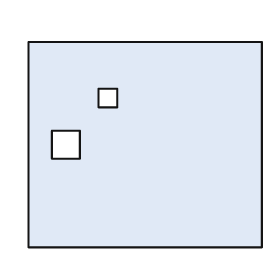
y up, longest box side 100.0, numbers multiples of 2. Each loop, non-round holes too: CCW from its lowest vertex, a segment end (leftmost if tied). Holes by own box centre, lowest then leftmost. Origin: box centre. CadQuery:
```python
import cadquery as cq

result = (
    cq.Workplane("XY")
    .moveTo(-50.0, -44.0)
    .lineTo(50.0, -44.0)
    .lineTo(50.0, 44.0)
    .lineTo(-50.0, 44.0)
    .close()
    .moveTo(-40.0, -6.0)
    .lineTo(-28.0, -6.0)
    .lineTo(-28.0, 6.0)
    .lineTo(-40.0, 6.0)
    .close()
    .moveTo(-20.0, 16.0)
    .lineTo(-12.0, 16.0)
    .lineTo(-12.0, 24.0)
    .lineTo(-20.0, 24.0)
    .close()
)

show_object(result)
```